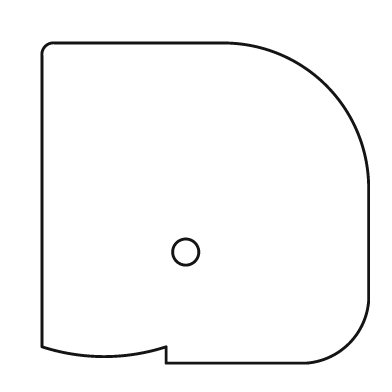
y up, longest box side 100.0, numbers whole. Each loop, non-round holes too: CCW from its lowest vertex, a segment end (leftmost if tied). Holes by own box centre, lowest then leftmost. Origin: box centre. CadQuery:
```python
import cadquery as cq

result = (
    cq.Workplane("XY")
    .moveTo(-12.0, -49.0)
    .lineTo(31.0, -49.0)
    .threePointArc((44.0, -43.0), (50.0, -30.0))
    .lineTo(50.0, 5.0)
    .threePointArc((37.0, 36.0), (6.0, 49.0))
    .lineTo(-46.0, 49.0)
    .threePointArc((-49.0, 48.0), (-50.0, 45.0))
    .lineTo(-50.0, -44.0)
    .threePointArc((-31.0, -47.0), (-12.0, -44.0))
    .close()
    .moveTo(-6.0, -15.0)
    .circle(4.0)
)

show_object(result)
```